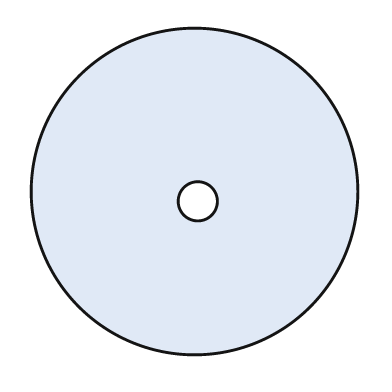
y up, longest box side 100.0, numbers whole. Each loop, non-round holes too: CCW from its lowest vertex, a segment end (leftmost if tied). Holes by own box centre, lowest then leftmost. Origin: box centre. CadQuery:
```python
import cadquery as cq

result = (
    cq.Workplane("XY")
    .moveTo(0.0, 0.0)
    .circle(50.0)
    .moveTo(1.0, -3.0)
    .circle(6.0)
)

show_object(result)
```